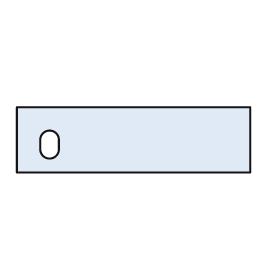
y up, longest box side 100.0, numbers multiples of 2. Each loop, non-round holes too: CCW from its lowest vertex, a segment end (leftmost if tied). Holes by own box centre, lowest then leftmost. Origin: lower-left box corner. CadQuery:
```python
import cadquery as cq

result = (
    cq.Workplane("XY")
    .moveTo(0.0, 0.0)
    .lineTo(100.0, 0.0)
    .lineTo(100.0, 28.0)
    .lineTo(0.0, 28.0)
    .close()
    .moveTo(10.0, 10.0)
    .threePointArc((14.0, 6.0), (18.0, 10.0))
    .lineTo(18.0, 14.0)
    .threePointArc((14.0, 18.0), (10.0, 14.0))
    .close()
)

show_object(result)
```